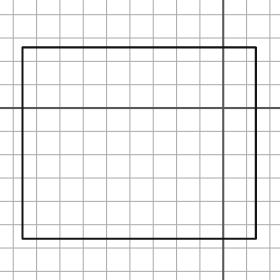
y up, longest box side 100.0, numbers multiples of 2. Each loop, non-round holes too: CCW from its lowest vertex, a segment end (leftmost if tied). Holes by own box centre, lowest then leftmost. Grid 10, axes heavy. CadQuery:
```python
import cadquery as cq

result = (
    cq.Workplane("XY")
    .moveTo(-86.0, -56.0)
    .lineTo(14.0, -56.0)
    .lineTo(14.0, 26.0)
    .lineTo(-86.0, 26.0)
    .close()
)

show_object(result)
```